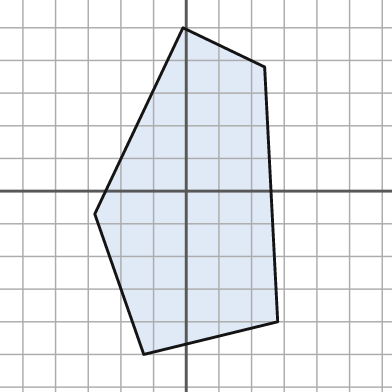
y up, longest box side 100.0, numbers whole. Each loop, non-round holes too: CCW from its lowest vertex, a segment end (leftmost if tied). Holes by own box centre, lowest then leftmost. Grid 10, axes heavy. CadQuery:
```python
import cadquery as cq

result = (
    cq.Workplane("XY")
    .moveTo(-13.0, -50.0)
    .lineTo(28.0, -40.0)
    .lineTo(24.0, 38.0)
    .lineTo(-1.0, 50.0)
    .lineTo(-28.0, -7.0)
    .close()
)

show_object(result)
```